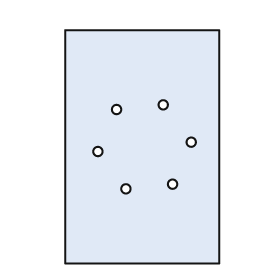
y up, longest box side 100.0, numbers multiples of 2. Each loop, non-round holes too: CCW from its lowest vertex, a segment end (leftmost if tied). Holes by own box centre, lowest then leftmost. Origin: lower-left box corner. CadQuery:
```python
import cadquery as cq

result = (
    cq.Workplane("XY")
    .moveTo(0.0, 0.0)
    .lineTo(66.0, 0.0)
    .lineTo(66.0, 100.0)
    .lineTo(0.0, 100.0)
    .close()
    .moveTo(26.0, 32.0)
    .circle(2.0)
    .moveTo(46.0, 34.0)
    .circle(2.0)
    .moveTo(14.0, 48.0)
    .circle(2.0)
    .moveTo(54.0, 52.0)
    .circle(2.0)
    .moveTo(22.0, 66.0)
    .circle(2.0)
    .moveTo(42.0, 68.0)
    .circle(2.0)
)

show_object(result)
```